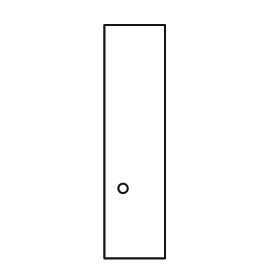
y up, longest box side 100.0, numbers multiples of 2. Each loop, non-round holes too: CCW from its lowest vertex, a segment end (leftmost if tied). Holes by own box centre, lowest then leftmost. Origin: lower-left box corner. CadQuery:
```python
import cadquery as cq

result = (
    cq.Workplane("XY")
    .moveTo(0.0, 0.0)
    .lineTo(26.0, 0.0)
    .lineTo(26.0, 100.0)
    .lineTo(0.0, 100.0)
    .close()
    .moveTo(8.0, 30.0)
    .circle(2.0)
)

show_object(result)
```